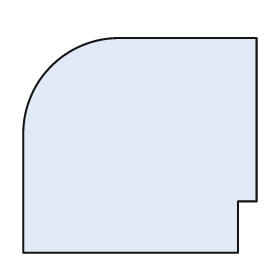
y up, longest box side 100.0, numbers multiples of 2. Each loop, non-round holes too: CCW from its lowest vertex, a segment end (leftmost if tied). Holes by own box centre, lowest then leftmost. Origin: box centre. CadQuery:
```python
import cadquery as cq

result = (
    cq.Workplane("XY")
    .moveTo(-50.0, -46.0)
    .lineTo(42.0, -46.0)
    .lineTo(42.0, -24.0)
    .lineTo(50.0, -24.0)
    .lineTo(50.0, 46.0)
    .lineTo(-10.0, 46.0)
    .threePointArc((-38.0, 34.0), (-50.0, 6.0))
    .close()
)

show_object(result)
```